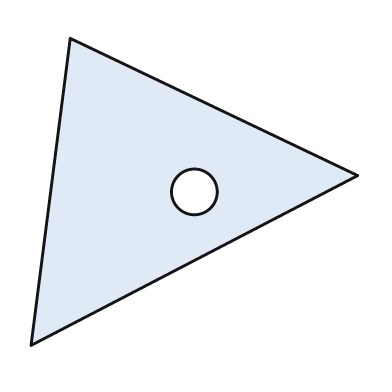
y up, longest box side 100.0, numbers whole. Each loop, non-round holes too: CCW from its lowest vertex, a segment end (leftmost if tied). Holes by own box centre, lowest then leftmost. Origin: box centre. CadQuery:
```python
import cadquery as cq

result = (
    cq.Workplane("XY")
    .moveTo(-50.0, -47.0)
    .lineTo(50.0, 5.0)
    .lineTo(-38.0, 47.0)
    .close()
    .moveTo(0.0, 0.0)
    .circle(7.0)
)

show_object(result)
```